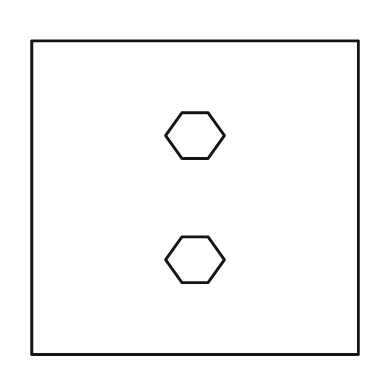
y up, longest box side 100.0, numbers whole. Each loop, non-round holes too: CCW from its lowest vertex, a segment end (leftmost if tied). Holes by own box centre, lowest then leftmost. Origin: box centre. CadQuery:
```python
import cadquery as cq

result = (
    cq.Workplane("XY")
    .moveTo(-50.0, -48.0)
    .lineTo(50.0, -48.0)
    .lineTo(50.0, 48.0)
    .lineTo(-50.0, 48.0)
    .close()
    .moveTo(-4.0, -26.0)
    .lineTo(4.0, -26.0)
    .lineTo(9.0, -19.0)
    .lineTo(4.0, -12.0)
    .lineTo(-4.0, -12.0)
    .lineTo(-9.0, -19.0)
    .close()
    .moveTo(-4.0, 12.0)
    .lineTo(4.0, 12.0)
    .lineTo(9.0, 19.0)
    .lineTo(4.0, 26.0)
    .lineTo(-4.0, 26.0)
    .lineTo(-9.0, 19.0)
    .close()
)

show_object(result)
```